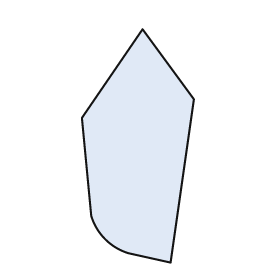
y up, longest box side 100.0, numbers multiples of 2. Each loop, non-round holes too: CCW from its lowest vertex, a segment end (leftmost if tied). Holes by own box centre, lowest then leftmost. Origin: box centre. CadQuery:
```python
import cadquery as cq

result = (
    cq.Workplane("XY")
    .moveTo(14.0, -50.0)
    .lineTo(24.0, 20.0)
    .lineTo(2.0, 50.0)
    .lineTo(-24.0, 12.0)
    .lineTo(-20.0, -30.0)
    .threePointArc((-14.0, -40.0), (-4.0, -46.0))
    .close()
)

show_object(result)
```